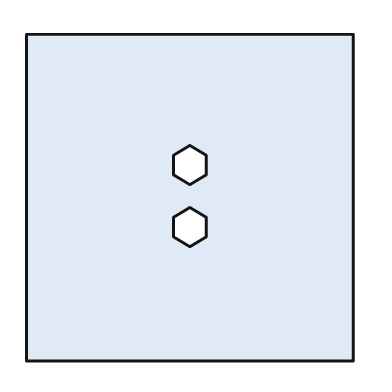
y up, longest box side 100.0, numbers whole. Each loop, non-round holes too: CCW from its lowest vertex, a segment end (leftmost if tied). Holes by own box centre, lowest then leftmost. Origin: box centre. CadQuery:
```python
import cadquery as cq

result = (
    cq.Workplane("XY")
    .moveTo(-50.0, -50.0)
    .lineTo(50.0, -50.0)
    .lineTo(50.0, 50.0)
    .lineTo(-50.0, 50.0)
    .close()
    .moveTo(0.0, -15.0)
    .lineTo(5.0, -12.0)
    .lineTo(5.0, -6.0)
    .lineTo(0.0, -3.0)
    .lineTo(-5.0, -6.0)
    .lineTo(-5.0, -12.0)
    .close()
    .moveTo(0.0, 4.0)
    .lineTo(5.0, 7.0)
    .lineTo(5.0, 13.0)
    .lineTo(0.0, 16.0)
    .lineTo(-5.0, 13.0)
    .lineTo(-5.0, 7.0)
    .close()
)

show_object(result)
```